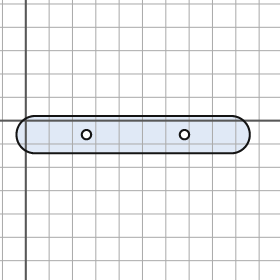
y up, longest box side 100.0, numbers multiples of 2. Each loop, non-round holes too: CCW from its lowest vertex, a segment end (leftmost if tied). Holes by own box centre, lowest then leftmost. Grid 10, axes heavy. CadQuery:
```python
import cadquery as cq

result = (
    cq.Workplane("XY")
    .moveTo(4.0, -14.0)
    .lineTo(88.0, -14.0)
    .threePointArc((96.0, -6.0), (88.0, 2.0))
    .lineTo(4.0, 2.0)
    .threePointArc((-4.0, -6.0), (4.0, -14.0))
    .close()
    .moveTo(26.0, -6.0)
    .circle(2.0)
    .moveTo(68.0, -6.0)
    .circle(2.0)
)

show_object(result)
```